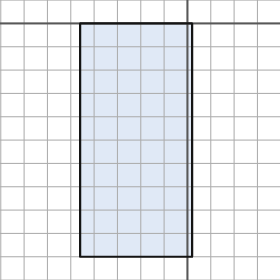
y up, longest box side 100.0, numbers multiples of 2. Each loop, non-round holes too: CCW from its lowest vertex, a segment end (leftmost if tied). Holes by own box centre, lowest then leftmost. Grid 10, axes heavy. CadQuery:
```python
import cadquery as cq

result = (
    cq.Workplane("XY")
    .moveTo(-46.0, -100.0)
    .lineTo(2.0, -100.0)
    .lineTo(2.0, 0.0)
    .lineTo(-46.0, 0.0)
    .close()
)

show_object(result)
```